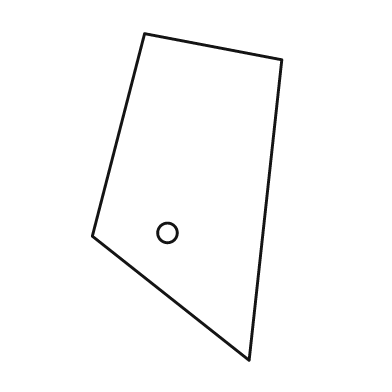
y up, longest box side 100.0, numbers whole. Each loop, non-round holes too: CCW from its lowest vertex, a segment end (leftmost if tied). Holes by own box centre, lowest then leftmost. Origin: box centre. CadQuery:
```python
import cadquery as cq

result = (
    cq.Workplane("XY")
    .moveTo(19.0, -50.0)
    .lineTo(29.0, 42.0)
    .lineTo(-13.0, 50.0)
    .lineTo(-29.0, -12.0)
    .close()
    .moveTo(-6.0, -11.0)
    .circle(3.0)
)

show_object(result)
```